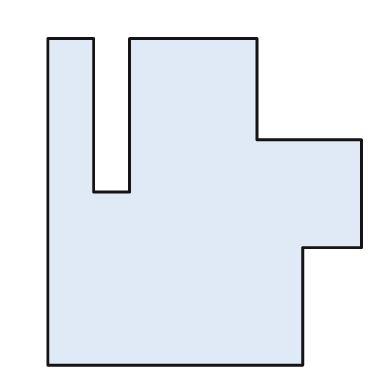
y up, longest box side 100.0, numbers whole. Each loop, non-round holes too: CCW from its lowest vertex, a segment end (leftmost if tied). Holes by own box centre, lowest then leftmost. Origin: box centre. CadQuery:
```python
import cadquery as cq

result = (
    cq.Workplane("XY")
    .moveTo(-48.0, -50.0)
    .lineTo(30.0, -50.0)
    .lineTo(30.0, -14.0)
    .lineTo(48.0, -14.0)
    .lineTo(48.0, 19.0)
    .lineTo(16.0, 19.0)
    .lineTo(16.0, 50.0)
    .lineTo(-23.0, 50.0)
    .lineTo(-23.0, 3.0)
    .lineTo(-34.0, 3.0)
    .lineTo(-34.0, 50.0)
    .lineTo(-48.0, 50.0)
    .close()
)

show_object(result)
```